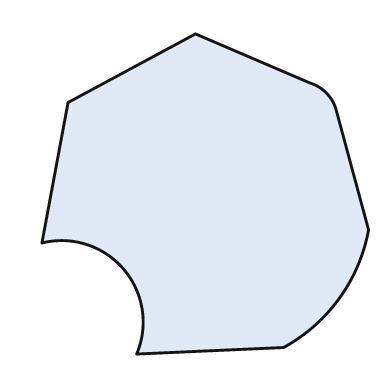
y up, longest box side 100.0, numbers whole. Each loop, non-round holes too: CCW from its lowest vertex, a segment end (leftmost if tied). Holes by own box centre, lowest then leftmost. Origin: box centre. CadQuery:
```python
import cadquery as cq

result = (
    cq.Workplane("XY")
    .moveTo(-21.0, -49.0)
    .lineTo(24.0, -47.0)
    .threePointArc((41.0, -32.0), (50.0, -11.0))
    .lineTo(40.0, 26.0)
    .threePointArc((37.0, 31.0), (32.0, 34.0))
    .lineTo(-3.0, 49.0)
    .lineTo(-42.0, 28.0)
    .lineTo(-50.0, -15.0)
    .threePointArc((-25.0, -23.0), (-21.0, -49.0))
    .close()
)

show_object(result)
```